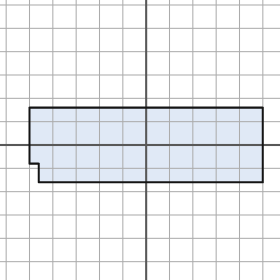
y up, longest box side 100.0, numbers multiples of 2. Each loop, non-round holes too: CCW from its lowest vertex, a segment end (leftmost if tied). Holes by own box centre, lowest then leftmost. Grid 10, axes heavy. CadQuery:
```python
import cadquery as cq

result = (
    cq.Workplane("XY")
    .moveTo(-46.0, -16.0)
    .lineTo(50.0, -16.0)
    .lineTo(50.0, 16.0)
    .lineTo(-50.0, 16.0)
    .lineTo(-50.0, -8.0)
    .lineTo(-46.0, -8.0)
    .close()
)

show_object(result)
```